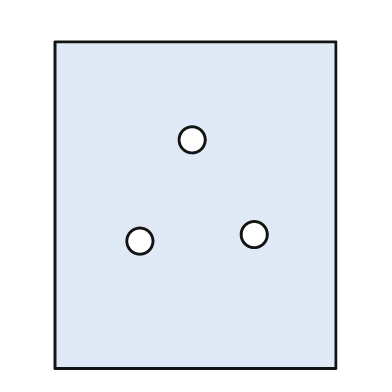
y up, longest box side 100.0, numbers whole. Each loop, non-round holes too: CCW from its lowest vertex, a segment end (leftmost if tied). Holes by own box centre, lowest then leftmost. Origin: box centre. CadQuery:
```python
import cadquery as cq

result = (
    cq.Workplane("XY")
    .moveTo(-43.0, -50.0)
    .lineTo(43.0, -50.0)
    .lineTo(43.0, 50.0)
    .lineTo(-43.0, 50.0)
    .close()
    .moveTo(-17.0, -11.0)
    .circle(4.0)
    .moveTo(18.0, -9.0)
    .circle(4.0)
    .moveTo(-1.0, 20.0)
    .circle(4.0)
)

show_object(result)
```